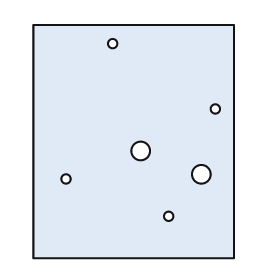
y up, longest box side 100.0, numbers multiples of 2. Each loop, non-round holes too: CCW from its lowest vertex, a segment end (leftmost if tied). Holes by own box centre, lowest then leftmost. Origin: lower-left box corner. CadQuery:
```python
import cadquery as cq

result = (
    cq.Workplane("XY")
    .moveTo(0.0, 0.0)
    .lineTo(86.0, 0.0)
    .lineTo(86.0, 100.0)
    .lineTo(0.0, 100.0)
    .close()
    .moveTo(58.0, 18.0)
    .circle(2.0)
    .moveTo(14.0, 34.0)
    .circle(2.0)
    .moveTo(72.0, 36.0)
    .circle(4.0)
    .moveTo(46.0, 46.0)
    .circle(4.0)
    .moveTo(78.0, 64.0)
    .circle(2.0)
    .moveTo(34.0, 92.0)
    .circle(2.0)
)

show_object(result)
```